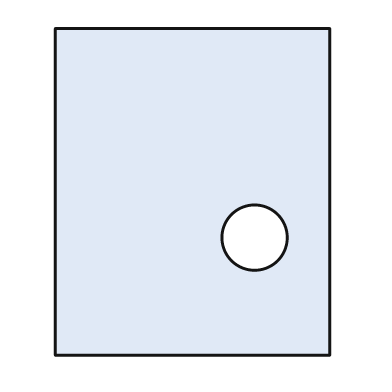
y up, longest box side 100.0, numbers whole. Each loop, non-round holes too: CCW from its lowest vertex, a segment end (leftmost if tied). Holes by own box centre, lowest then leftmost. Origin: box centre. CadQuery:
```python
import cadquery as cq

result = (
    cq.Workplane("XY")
    .moveTo(-42.0, -50.0)
    .lineTo(42.0, -50.0)
    .lineTo(42.0, 50.0)
    .lineTo(-42.0, 50.0)
    .close()
    .moveTo(19.0, -14.0)
    .circle(10.0)
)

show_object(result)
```